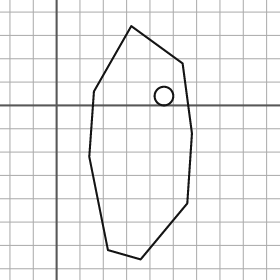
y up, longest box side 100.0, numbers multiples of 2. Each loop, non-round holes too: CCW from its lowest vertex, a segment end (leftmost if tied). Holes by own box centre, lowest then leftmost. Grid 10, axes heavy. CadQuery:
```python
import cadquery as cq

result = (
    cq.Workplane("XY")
    .moveTo(36.0, -66.0)
    .lineTo(56.0, -42.0)
    .lineTo(58.0, -12.0)
    .lineTo(54.0, 18.0)
    .lineTo(32.0, 34.0)
    .lineTo(16.0, 6.0)
    .lineTo(14.0, -22.0)
    .lineTo(22.0, -62.0)
    .close()
    .moveTo(46.0, 4.0)
    .circle(4.0)
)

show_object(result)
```